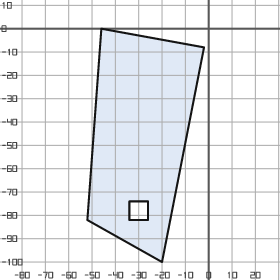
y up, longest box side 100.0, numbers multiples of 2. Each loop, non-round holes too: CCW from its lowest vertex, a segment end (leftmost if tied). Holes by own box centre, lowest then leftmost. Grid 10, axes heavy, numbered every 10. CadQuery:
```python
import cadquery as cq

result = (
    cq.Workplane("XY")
    .moveTo(-20.0, -100.0)
    .lineTo(-2.0, -8.0)
    .lineTo(-46.0, 0.0)
    .lineTo(-52.0, -82.0)
    .close()
    .moveTo(-34.0, -82.0)
    .lineTo(-26.0, -82.0)
    .lineTo(-26.0, -74.0)
    .lineTo(-34.0, -74.0)
    .close()
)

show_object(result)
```